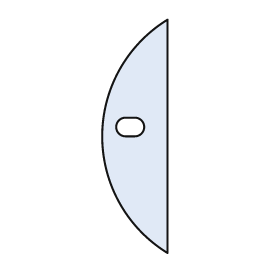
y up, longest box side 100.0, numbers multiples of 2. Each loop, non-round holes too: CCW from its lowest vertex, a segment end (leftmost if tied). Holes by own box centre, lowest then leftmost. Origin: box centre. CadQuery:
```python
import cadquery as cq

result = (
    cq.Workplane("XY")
    .moveTo(14.0, -50.0)
    .lineTo(14.0, 50.0)
    .threePointArc((-14.0, 0.0), (14.0, -50.0))
    .close()
    .moveTo(-4.0, 0.0)
    .lineTo(0.0, 0.0)
    .threePointArc((4.0, 4.0), (0.0, 8.0))
    .lineTo(-4.0, 8.0)
    .threePointArc((-8.0, 4.0), (-4.0, 0.0))
    .close()
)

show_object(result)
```